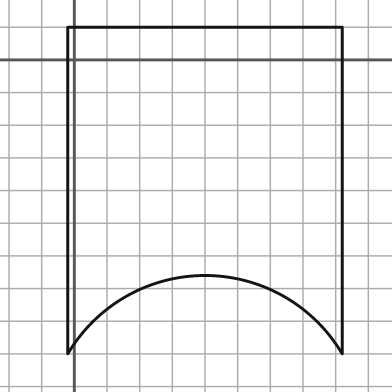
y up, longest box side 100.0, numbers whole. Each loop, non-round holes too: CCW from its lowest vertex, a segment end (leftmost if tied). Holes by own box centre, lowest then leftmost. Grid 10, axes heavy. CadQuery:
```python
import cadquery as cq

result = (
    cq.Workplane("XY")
    .moveTo(-2.0, -90.0)
    .threePointArc((40.0, -66.0), (82.0, -90.0))
    .lineTo(82.0, 10.0)
    .lineTo(-2.0, 10.0)
    .close()
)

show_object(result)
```